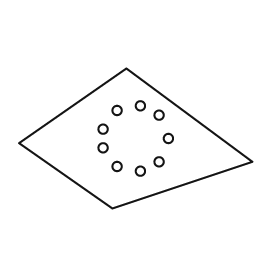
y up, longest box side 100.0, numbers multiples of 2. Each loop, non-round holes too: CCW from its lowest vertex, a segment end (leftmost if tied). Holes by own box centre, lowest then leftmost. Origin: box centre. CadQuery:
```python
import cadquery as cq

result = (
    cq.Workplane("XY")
    .moveTo(-10.0, -30.0)
    .lineTo(50.0, -10.0)
    .lineTo(-4.0, 30.0)
    .lineTo(-50.0, -2.0)
    .close()
    .moveTo(2.0, -14.0)
    .circle(2.0)
    .moveTo(-8.0, -12.0)
    .circle(2.0)
    .moveTo(10.0, -10.0)
    .circle(2.0)
    .moveTo(-14.0, -4.0)
    .circle(2.0)
    .moveTo(14.0, 0.0)
    .circle(2.0)
    .moveTo(-14.0, 4.0)
    .circle(2.0)
    .moveTo(10.0, 10.0)
    .circle(2.0)
    .moveTo(-8.0, 12.0)
    .circle(2.0)
    .moveTo(2.0, 14.0)
    .circle(2.0)
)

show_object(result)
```